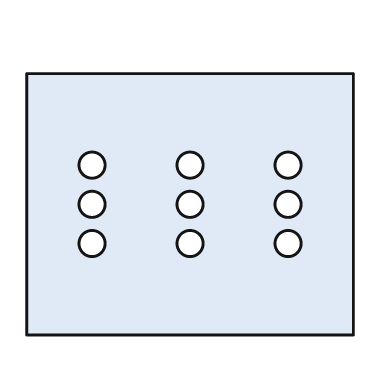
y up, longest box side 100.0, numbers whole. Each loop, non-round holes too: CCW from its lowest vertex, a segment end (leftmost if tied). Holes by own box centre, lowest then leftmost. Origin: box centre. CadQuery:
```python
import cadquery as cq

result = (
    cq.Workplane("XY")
    .moveTo(-50.0, -40.0)
    .lineTo(50.0, -40.0)
    .lineTo(50.0, 40.0)
    .lineTo(-50.0, 40.0)
    .close()
    .moveTo(-30.0, -12.0)
    .circle(4.0)
    .moveTo(0.0, -12.0)
    .circle(4.0)
    .moveTo(30.0, -12.0)
    .circle(4.0)
    .moveTo(-30.0, 0.0)
    .circle(4.0)
    .moveTo(0.0, 0.0)
    .circle(4.0)
    .moveTo(30.0, 0.0)
    .circle(4.0)
    .moveTo(-30.0, 12.0)
    .circle(4.0)
    .moveTo(0.0, 12.0)
    .circle(4.0)
    .moveTo(30.0, 12.0)
    .circle(4.0)
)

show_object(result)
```